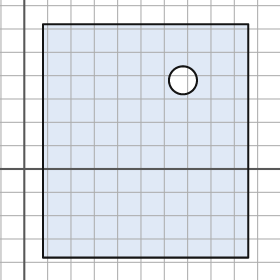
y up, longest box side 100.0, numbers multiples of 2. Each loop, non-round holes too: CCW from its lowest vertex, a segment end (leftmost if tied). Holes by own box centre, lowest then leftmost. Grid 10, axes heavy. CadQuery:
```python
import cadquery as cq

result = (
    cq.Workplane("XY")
    .moveTo(8.0, -38.0)
    .lineTo(96.0, -38.0)
    .lineTo(96.0, 62.0)
    .lineTo(8.0, 62.0)
    .close()
    .moveTo(68.0, 38.0)
    .circle(6.0)
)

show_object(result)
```